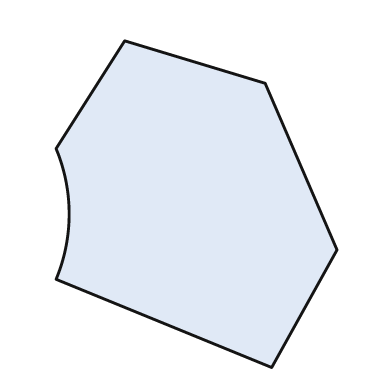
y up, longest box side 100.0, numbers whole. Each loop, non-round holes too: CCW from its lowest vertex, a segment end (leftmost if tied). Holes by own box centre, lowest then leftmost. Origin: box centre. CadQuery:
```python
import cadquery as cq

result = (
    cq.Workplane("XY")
    .moveTo(23.0, -50.0)
    .lineTo(43.0, -14.0)
    .lineTo(21.0, 37.0)
    .lineTo(-22.0, 50.0)
    .lineTo(-43.0, 17.0)
    .threePointArc((-39.0, -3.0), (-43.0, -23.0))
    .close()
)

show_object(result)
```